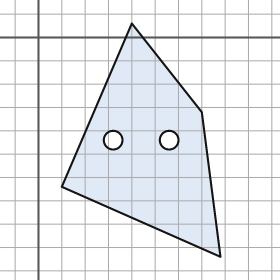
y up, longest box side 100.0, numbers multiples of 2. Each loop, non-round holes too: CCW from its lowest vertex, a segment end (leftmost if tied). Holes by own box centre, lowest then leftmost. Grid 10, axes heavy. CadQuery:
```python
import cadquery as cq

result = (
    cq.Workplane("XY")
    .moveTo(78.0, -94.0)
    .lineTo(70.0, -32.0)
    .lineTo(40.0, 6.0)
    .lineTo(10.0, -64.0)
    .close()
    .moveTo(32.0, -44.0)
    .circle(4.0)
    .moveTo(56.0, -44.0)
    .circle(4.0)
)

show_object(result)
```